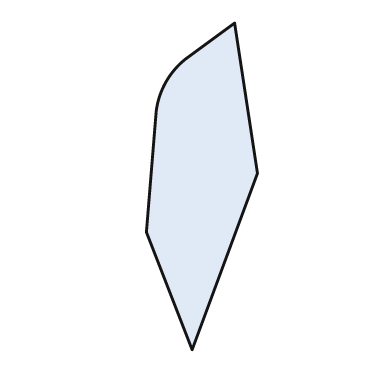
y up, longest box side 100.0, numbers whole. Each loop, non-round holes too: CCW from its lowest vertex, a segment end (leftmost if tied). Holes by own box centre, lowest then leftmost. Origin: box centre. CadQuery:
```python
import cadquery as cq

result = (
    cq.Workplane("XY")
    .moveTo(-3.0, -50.0)
    .lineTo(17.0, 4.0)
    .lineTo(10.0, 50.0)
    .lineTo(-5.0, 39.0)
    .threePointArc((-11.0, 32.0), (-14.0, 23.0))
    .lineTo(-17.0, -14.0)
    .close()
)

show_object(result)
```